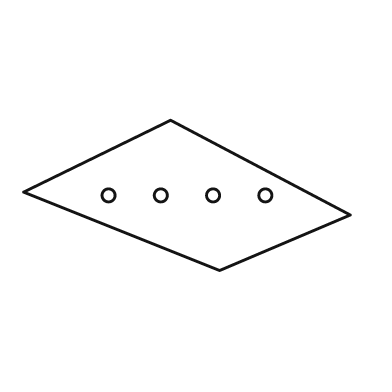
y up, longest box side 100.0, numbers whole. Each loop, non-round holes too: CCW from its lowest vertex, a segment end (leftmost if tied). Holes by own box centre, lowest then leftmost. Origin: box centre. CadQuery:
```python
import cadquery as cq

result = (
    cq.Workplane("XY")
    .moveTo(10.0, -23.0)
    .lineTo(50.0, -6.0)
    .lineTo(-5.0, 23.0)
    .lineTo(-50.0, 1.0)
    .close()
    .moveTo(-24.0, 0.0)
    .circle(2.0)
    .moveTo(-8.0, 0.0)
    .circle(2.0)
    .moveTo(8.0, 0.0)
    .circle(2.0)
    .moveTo(24.0, 0.0)
    .circle(2.0)
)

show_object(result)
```